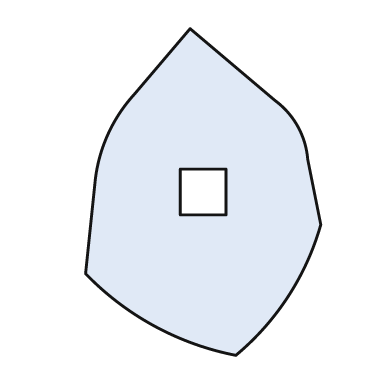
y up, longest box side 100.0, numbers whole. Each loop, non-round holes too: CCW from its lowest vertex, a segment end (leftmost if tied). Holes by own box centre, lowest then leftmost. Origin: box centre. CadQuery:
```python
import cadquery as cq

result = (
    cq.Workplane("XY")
    .moveTo(10.0, -50.0)
    .threePointArc((26.0, -32.0), (36.0, -10.0))
    .lineTo(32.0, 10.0)
    .threePointArc((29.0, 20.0), (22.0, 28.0))
    .lineTo(-4.0, 50.0)
    .lineTo(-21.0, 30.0)
    .threePointArc((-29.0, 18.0), (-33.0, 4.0))
    .lineTo(-36.0, -25.0)
    .threePointArc((-15.0, -41.0), (10.0, -50.0))
    .close()
    .moveTo(-7.0, -7.0)
    .lineTo(7.0, -7.0)
    .lineTo(7.0, 7.0)
    .lineTo(-7.0, 7.0)
    .close()
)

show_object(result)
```